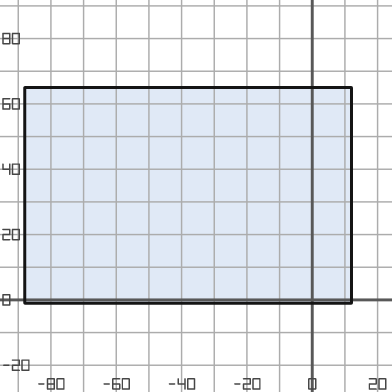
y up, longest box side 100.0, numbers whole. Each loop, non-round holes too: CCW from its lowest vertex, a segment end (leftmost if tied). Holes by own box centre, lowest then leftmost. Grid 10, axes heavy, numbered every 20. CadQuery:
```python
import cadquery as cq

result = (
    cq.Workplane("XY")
    .moveTo(-88.0, -1.0)
    .lineTo(12.0, -1.0)
    .lineTo(12.0, 65.0)
    .lineTo(-88.0, 65.0)
    .close()
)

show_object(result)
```